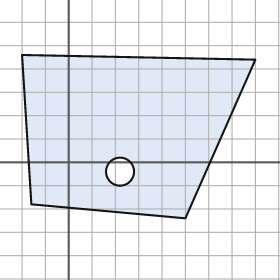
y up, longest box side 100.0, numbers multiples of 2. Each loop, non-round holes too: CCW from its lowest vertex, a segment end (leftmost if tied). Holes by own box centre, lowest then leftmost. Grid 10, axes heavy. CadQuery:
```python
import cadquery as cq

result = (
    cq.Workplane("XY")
    .moveTo(50.0, -24.0)
    .lineTo(80.0, 44.0)
    .lineTo(-20.0, 46.0)
    .lineTo(-16.0, -18.0)
    .close()
    .moveTo(22.0, -4.0)
    .circle(6.0)
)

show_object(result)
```